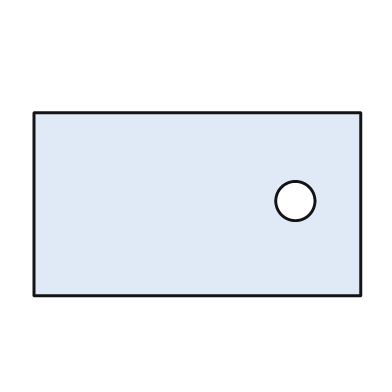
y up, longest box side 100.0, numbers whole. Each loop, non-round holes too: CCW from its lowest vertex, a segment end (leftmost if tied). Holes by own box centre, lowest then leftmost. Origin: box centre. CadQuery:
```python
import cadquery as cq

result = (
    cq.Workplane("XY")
    .moveTo(-50.0, -28.0)
    .lineTo(50.0, -28.0)
    .lineTo(50.0, 28.0)
    .lineTo(-50.0, 28.0)
    .close()
    .moveTo(30.0, 1.0)
    .circle(6.0)
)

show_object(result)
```